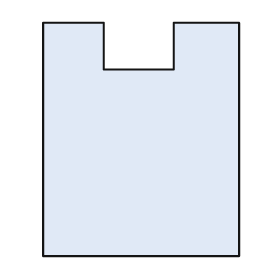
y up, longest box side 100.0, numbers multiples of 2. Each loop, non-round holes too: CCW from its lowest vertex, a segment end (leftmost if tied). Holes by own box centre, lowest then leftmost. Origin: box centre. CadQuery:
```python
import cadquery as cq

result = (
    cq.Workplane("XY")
    .moveTo(-42.0, -50.0)
    .lineTo(42.0, -50.0)
    .lineTo(42.0, 50.0)
    .lineTo(14.0, 50.0)
    .lineTo(14.0, 30.0)
    .lineTo(-16.0, 30.0)
    .lineTo(-16.0, 50.0)
    .lineTo(-42.0, 50.0)
    .close()
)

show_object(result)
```